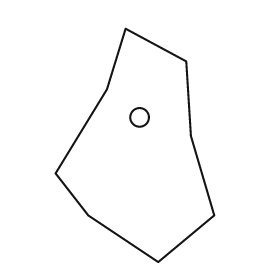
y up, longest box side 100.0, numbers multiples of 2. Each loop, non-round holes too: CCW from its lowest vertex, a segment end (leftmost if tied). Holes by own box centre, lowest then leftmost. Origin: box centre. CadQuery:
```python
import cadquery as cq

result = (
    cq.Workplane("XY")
    .moveTo(10.0, -50.0)
    .lineTo(34.0, -30.0)
    .lineTo(24.0, 4.0)
    .lineTo(22.0, 36.0)
    .lineTo(-4.0, 50.0)
    .lineTo(-12.0, 24.0)
    .lineTo(-34.0, -12.0)
    .lineTo(-20.0, -30.0)
    .close()
    .moveTo(2.0, 12.0)
    .circle(4.0)
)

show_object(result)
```